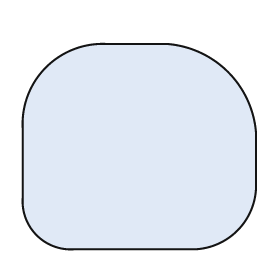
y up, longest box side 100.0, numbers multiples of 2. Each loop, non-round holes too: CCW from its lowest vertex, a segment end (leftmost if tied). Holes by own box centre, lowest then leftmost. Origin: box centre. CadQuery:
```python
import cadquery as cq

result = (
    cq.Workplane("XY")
    .moveTo(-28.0, -44.0)
    .lineTo(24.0, -44.0)
    .threePointArc((42.0, -36.0), (50.0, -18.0))
    .lineTo(50.0, 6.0)
    .threePointArc((38.0, 32.0), (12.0, 44.0))
    .lineTo(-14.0, 44.0)
    .threePointArc((-40.0, 34.0), (-50.0, 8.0))
    .lineTo(-50.0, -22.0)
    .threePointArc((-44.0, -38.0), (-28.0, -44.0))
    .close()
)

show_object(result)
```